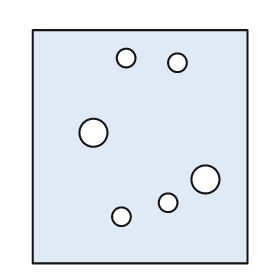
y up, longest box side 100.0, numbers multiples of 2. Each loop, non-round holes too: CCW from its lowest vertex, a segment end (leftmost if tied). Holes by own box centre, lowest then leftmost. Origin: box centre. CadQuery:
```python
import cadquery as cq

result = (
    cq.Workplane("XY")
    .moveTo(-46.0, -50.0)
    .lineTo(46.0, -50.0)
    .lineTo(46.0, 50.0)
    .lineTo(-46.0, 50.0)
    .close()
    .moveTo(-8.0, -30.0)
    .circle(4.0)
    .moveTo(12.0, -24.0)
    .circle(4.0)
    .moveTo(28.0, -14.0)
    .circle(6.0)
    .moveTo(-20.0, 6.0)
    .circle(6.0)
    .moveTo(16.0, 36.0)
    .circle(4.0)
    .moveTo(-6.0, 38.0)
    .circle(4.0)
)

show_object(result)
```